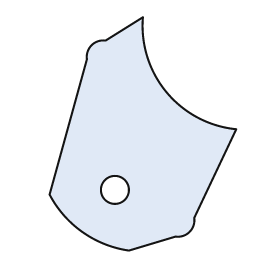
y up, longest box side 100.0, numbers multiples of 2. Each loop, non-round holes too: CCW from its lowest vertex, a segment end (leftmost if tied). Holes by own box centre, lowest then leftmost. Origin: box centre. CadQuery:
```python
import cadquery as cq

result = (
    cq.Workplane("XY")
    .moveTo(-6.0, -50.0)
    .lineTo(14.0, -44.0)
    .threePointArc((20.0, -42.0), (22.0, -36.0))
    .lineTo(40.0, 2.0)
    .threePointArc((10.0, 18.0), (0.0, 50.0))
    .lineTo(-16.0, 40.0)
    .threePointArc((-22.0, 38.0), (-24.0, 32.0))
    .lineTo(-40.0, -26.0)
    .threePointArc((-26.0, -42.0), (-6.0, -50.0))
    .close()
    .moveTo(-12.0, -24.0)
    .circle(6.0)
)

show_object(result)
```